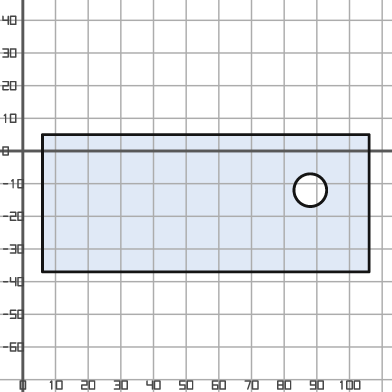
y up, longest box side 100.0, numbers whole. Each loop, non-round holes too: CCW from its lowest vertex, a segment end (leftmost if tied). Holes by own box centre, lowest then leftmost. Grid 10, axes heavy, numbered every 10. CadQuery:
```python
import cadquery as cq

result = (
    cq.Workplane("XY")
    .moveTo(6.0, -37.0)
    .lineTo(106.0, -37.0)
    .lineTo(106.0, 5.0)
    .lineTo(6.0, 5.0)
    .close()
    .moveTo(88.0, -12.0)
    .circle(5.0)
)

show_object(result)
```